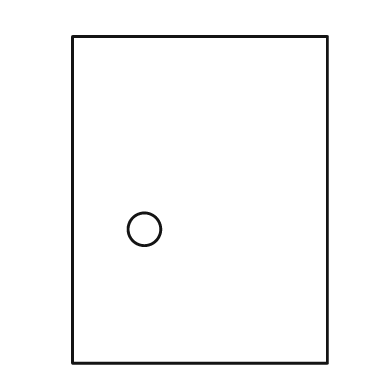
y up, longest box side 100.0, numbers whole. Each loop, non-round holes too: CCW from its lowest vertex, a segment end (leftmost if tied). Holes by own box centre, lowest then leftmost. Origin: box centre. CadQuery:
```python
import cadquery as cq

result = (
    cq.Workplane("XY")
    .moveTo(-39.0, -50.0)
    .lineTo(39.0, -50.0)
    .lineTo(39.0, 50.0)
    .lineTo(-39.0, 50.0)
    .close()
    .moveTo(-17.0, -9.0)
    .circle(5.0)
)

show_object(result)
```